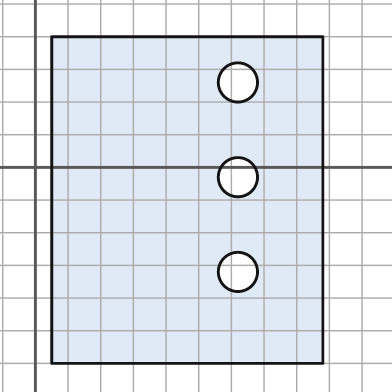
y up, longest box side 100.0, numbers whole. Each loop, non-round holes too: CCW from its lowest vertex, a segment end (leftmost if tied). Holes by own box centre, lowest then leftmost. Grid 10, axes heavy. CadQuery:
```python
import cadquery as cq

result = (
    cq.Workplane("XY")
    .moveTo(5.0, -60.0)
    .lineTo(88.0, -60.0)
    .lineTo(88.0, 40.0)
    .lineTo(5.0, 40.0)
    .close()
    .moveTo(62.0, -32.0)
    .circle(6.0)
    .moveTo(62.0, -3.0)
    .circle(6.0)
    .moveTo(62.0, 26.0)
    .circle(6.0)
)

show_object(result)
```